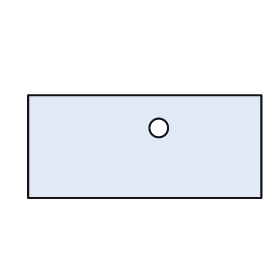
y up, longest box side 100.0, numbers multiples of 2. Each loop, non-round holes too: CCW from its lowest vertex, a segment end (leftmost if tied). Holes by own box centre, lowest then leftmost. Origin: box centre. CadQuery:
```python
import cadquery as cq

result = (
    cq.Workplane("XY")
    .moveTo(-50.0, -22.0)
    .lineTo(50.0, -22.0)
    .lineTo(50.0, 22.0)
    .lineTo(-50.0, 22.0)
    .close()
    .moveTo(6.0, 8.0)
    .circle(4.0)
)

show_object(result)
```